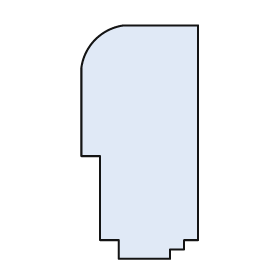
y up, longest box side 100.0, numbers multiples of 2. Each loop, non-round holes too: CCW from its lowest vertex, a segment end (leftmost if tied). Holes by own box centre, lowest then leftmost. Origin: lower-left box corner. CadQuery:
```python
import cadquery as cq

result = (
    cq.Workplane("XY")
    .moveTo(16.0, 0.0)
    .lineTo(38.0, 0.0)
    .lineTo(38.0, 4.0)
    .lineTo(44.0, 4.0)
    .lineTo(44.0, 8.0)
    .lineTo(50.0, 8.0)
    .lineTo(50.0, 100.0)
    .lineTo(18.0, 100.0)
    .threePointArc((6.0, 94.0), (0.0, 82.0))
    .lineTo(0.0, 44.0)
    .lineTo(8.0, 44.0)
    .lineTo(8.0, 8.0)
    .lineTo(16.0, 8.0)
    .close()
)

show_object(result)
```